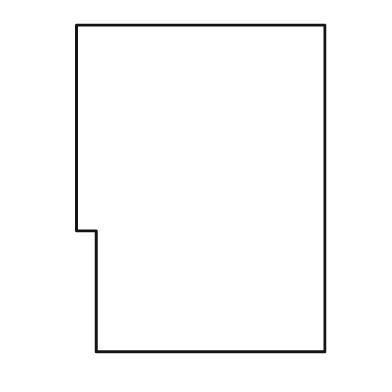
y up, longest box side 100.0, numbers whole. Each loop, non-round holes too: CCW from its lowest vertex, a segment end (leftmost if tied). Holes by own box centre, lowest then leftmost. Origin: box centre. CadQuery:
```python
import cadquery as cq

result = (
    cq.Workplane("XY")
    .moveTo(-32.0, -50.0)
    .lineTo(38.0, -50.0)
    .lineTo(38.0, 50.0)
    .lineTo(-38.0, 50.0)
    .lineTo(-38.0, -13.0)
    .lineTo(-32.0, -13.0)
    .close()
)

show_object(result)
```